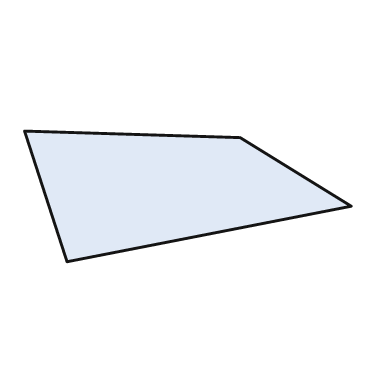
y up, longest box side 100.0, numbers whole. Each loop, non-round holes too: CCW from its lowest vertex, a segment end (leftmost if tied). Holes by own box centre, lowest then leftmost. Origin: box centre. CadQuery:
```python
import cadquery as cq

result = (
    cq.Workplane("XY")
    .moveTo(-37.0, -20.0)
    .lineTo(50.0, -3.0)
    .lineTo(16.0, 18.0)
    .lineTo(-50.0, 20.0)
    .close()
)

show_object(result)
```